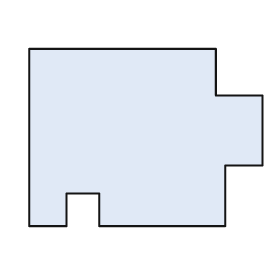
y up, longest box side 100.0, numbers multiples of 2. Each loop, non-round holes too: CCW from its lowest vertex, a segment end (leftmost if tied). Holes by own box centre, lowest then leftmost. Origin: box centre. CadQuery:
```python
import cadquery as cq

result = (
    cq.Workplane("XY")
    .moveTo(-50.0, -38.0)
    .lineTo(-34.0, -38.0)
    .lineTo(-34.0, -24.0)
    .lineTo(-20.0, -24.0)
    .lineTo(-20.0, -38.0)
    .lineTo(34.0, -38.0)
    .lineTo(34.0, -12.0)
    .lineTo(50.0, -12.0)
    .lineTo(50.0, 18.0)
    .lineTo(30.0, 18.0)
    .lineTo(30.0, 38.0)
    .lineTo(-50.0, 38.0)
    .close()
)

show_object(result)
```